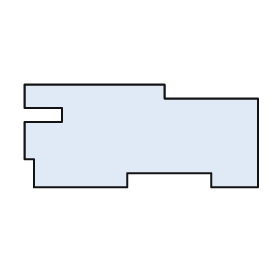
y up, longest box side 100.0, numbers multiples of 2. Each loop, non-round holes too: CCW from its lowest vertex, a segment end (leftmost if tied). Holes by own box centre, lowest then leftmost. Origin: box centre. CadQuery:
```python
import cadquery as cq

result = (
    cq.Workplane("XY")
    .moveTo(-46.0, -22.0)
    .lineTo(-6.0, -22.0)
    .lineTo(-6.0, -16.0)
    .lineTo(30.0, -16.0)
    .lineTo(30.0, -22.0)
    .lineTo(50.0, -22.0)
    .lineTo(50.0, 16.0)
    .lineTo(10.0, 16.0)
    .lineTo(10.0, 22.0)
    .lineTo(-50.0, 22.0)
    .lineTo(-50.0, 12.0)
    .lineTo(-34.0, 12.0)
    .lineTo(-34.0, 6.0)
    .lineTo(-50.0, 6.0)
    .lineTo(-50.0, -10.0)
    .lineTo(-46.0, -10.0)
    .close()
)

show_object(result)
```